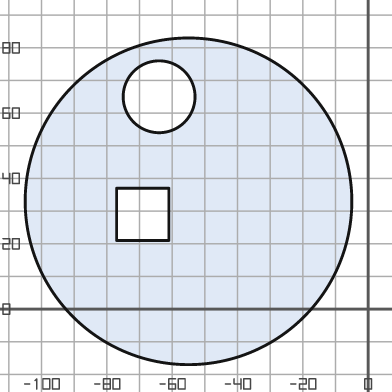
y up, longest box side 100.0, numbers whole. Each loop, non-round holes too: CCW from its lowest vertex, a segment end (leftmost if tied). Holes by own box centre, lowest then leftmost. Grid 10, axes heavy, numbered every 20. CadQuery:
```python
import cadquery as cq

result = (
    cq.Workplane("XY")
    .moveTo(-55.0, 33.0)
    .circle(50.0)
    .moveTo(-77.0, 21.0)
    .lineTo(-61.0, 21.0)
    .lineTo(-61.0, 37.0)
    .lineTo(-77.0, 37.0)
    .close()
    .moveTo(-64.0, 65.0)
    .circle(11.0)
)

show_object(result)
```